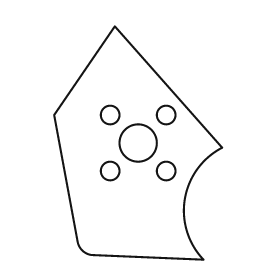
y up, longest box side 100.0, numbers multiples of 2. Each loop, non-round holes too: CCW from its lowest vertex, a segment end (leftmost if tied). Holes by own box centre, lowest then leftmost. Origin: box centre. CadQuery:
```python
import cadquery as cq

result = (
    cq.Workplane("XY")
    .moveTo(28.0, -50.0)
    .threePointArc((20.0, -24.0), (36.0, -2.0))
    .lineTo(-10.0, 50.0)
    .lineTo(-36.0, 12.0)
    .lineTo(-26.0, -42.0)
    .threePointArc((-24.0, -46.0), (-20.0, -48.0))
    .close()
    .moveTo(-12.0, -12.0)
    .circle(4.0)
    .moveTo(12.0, -12.0)
    .circle(4.0)
    .moveTo(0.0, 0.0)
    .circle(8.0)
    .moveTo(-12.0, 12.0)
    .circle(4.0)
    .moveTo(12.0, 12.0)
    .circle(4.0)
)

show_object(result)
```